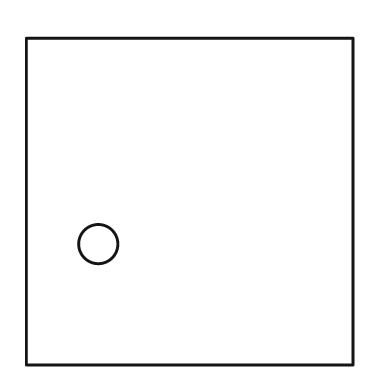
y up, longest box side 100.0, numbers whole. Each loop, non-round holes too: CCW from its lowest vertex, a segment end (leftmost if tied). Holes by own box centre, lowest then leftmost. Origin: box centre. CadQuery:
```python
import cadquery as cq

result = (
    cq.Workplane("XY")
    .moveTo(-50.0, -50.0)
    .lineTo(50.0, -50.0)
    .lineTo(50.0, 50.0)
    .lineTo(-50.0, 50.0)
    .close()
    .moveTo(-28.0, -13.0)
    .circle(6.0)
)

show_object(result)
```